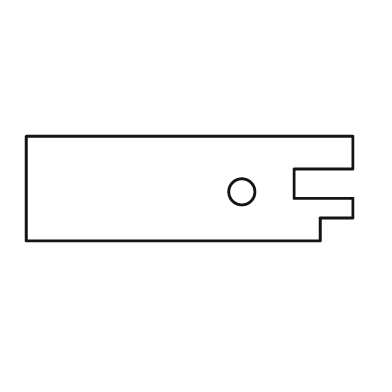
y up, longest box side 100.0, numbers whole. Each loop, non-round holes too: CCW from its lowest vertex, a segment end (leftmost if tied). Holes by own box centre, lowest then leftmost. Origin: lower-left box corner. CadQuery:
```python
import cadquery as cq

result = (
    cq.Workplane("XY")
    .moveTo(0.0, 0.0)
    .lineTo(90.0, 0.0)
    .lineTo(90.0, 7.0)
    .lineTo(100.0, 7.0)
    .lineTo(100.0, 13.0)
    .lineTo(82.0, 13.0)
    .lineTo(82.0, 22.0)
    .lineTo(100.0, 22.0)
    .lineTo(100.0, 32.0)
    .lineTo(0.0, 32.0)
    .close()
    .moveTo(66.0, 15.0)
    .circle(4.0)
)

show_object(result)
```